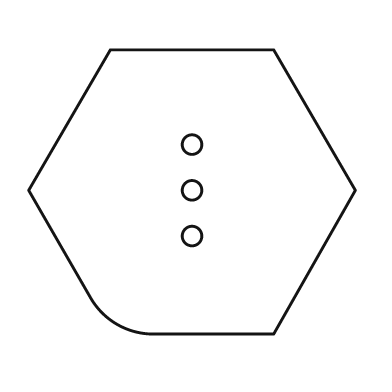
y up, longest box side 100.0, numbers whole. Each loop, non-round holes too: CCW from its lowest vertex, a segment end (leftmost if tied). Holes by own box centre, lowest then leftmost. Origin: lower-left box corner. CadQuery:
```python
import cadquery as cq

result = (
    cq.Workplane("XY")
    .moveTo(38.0, 0.0)
    .lineTo(75.0, 0.0)
    .lineTo(100.0, 44.0)
    .lineTo(75.0, 87.0)
    .lineTo(25.0, 87.0)
    .lineTo(0.0, 44.0)
    .lineTo(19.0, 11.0)
    .threePointArc((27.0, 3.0), (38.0, 0.0))
    .close()
    .moveTo(50.0, 30.0)
    .circle(3.0)
    .moveTo(50.0, 44.0)
    .circle(3.0)
    .moveTo(50.0, 58.0)
    .circle(3.0)
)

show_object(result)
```